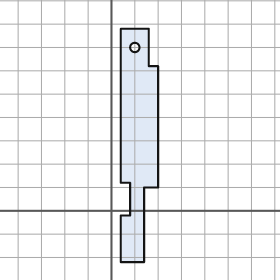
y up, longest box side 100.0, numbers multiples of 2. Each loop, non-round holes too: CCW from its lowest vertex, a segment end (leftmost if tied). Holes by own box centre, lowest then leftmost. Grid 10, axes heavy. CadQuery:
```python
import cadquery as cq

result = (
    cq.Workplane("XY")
    .moveTo(4.0, -22.0)
    .lineTo(14.0, -22.0)
    .lineTo(14.0, 10.0)
    .lineTo(20.0, 10.0)
    .lineTo(20.0, 62.0)
    .lineTo(16.0, 62.0)
    .lineTo(16.0, 78.0)
    .lineTo(4.0, 78.0)
    .lineTo(4.0, 12.0)
    .lineTo(8.0, 12.0)
    .lineTo(8.0, -2.0)
    .lineTo(4.0, -2.0)
    .close()
    .moveTo(10.0, 70.0)
    .circle(2.0)
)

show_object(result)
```